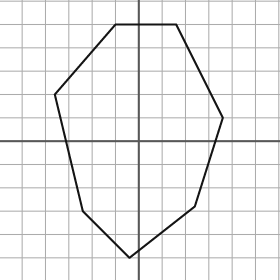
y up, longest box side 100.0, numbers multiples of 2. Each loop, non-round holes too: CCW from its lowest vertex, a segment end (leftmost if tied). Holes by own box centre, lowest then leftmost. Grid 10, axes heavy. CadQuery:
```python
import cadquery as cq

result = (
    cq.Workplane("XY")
    .moveTo(-4.0, -50.0)
    .lineTo(24.0, -28.0)
    .lineTo(36.0, 10.0)
    .lineTo(16.0, 50.0)
    .lineTo(-10.0, 50.0)
    .lineTo(-36.0, 20.0)
    .lineTo(-24.0, -30.0)
    .close()
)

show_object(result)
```